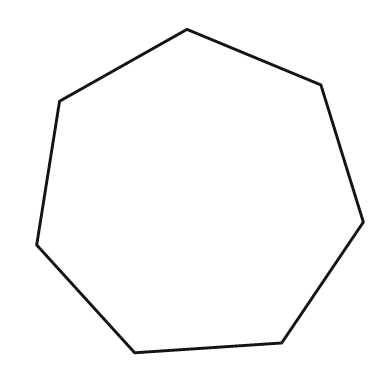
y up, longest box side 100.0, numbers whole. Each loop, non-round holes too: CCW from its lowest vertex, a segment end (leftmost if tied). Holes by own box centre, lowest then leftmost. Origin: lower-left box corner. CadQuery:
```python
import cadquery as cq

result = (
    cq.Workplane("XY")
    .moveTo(30.0, 0.0)
    .lineTo(75.0, 3.0)
    .lineTo(100.0, 40.0)
    .lineTo(87.0, 82.0)
    .lineTo(46.0, 99.0)
    .lineTo(7.0, 77.0)
    .lineTo(0.0, 33.0)
    .close()
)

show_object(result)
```